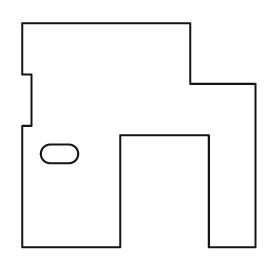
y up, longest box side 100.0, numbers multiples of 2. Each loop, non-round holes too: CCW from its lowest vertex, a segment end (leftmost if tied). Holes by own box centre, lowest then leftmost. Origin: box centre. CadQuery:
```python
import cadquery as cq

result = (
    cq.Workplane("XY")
    .moveTo(-50.0, -48.0)
    .lineTo(-8.0, -48.0)
    .lineTo(-8.0, 0.0)
    .lineTo(30.0, 0.0)
    .lineTo(30.0, -48.0)
    .lineTo(50.0, -48.0)
    .lineTo(50.0, 22.0)
    .lineTo(22.0, 22.0)
    .lineTo(22.0, 48.0)
    .lineTo(-50.0, 48.0)
    .lineTo(-50.0, 26.0)
    .lineTo(-46.0, 26.0)
    .lineTo(-46.0, 4.0)
    .lineTo(-50.0, 4.0)
    .close()
    .moveTo(-38.0, -12.0)
    .lineTo(-30.0, -12.0)
    .threePointArc((-26.0, -8.0), (-30.0, -4.0))
    .lineTo(-38.0, -4.0)
    .threePointArc((-42.0, -8.0), (-38.0, -12.0))
    .close()
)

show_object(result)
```